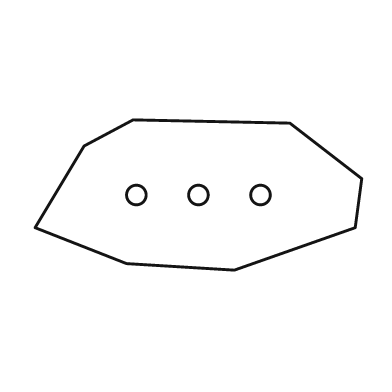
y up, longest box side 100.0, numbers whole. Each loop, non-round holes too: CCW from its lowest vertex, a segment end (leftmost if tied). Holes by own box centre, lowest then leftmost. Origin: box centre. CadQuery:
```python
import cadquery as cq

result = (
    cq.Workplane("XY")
    .moveTo(11.0, -23.0)
    .lineTo(48.0, -10.0)
    .lineTo(50.0, 5.0)
    .lineTo(28.0, 22.0)
    .lineTo(-20.0, 23.0)
    .lineTo(-35.0, 15.0)
    .lineTo(-50.0, -10.0)
    .lineTo(-22.0, -21.0)
    .close()
    .moveTo(-19.0, 0.0)
    .circle(3.0)
    .moveTo(0.0, 0.0)
    .circle(3.0)
    .moveTo(19.0, 0.0)
    .circle(3.0)
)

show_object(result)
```